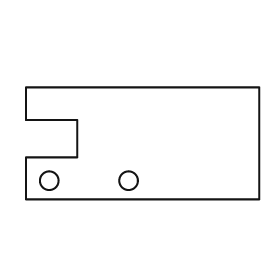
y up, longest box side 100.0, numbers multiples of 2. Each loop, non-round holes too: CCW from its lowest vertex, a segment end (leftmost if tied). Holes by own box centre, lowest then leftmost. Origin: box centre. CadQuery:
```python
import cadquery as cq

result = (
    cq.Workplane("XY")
    .moveTo(-50.0, -24.0)
    .lineTo(50.0, -24.0)
    .lineTo(50.0, 24.0)
    .lineTo(-50.0, 24.0)
    .lineTo(-50.0, 10.0)
    .lineTo(-28.0, 10.0)
    .lineTo(-28.0, -6.0)
    .lineTo(-50.0, -6.0)
    .close()
    .moveTo(-40.0, -16.0)
    .circle(4.0)
    .moveTo(-6.0, -16.0)
    .circle(4.0)
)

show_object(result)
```